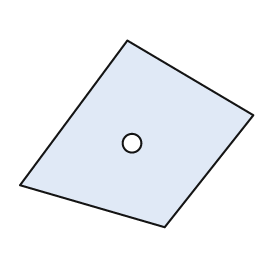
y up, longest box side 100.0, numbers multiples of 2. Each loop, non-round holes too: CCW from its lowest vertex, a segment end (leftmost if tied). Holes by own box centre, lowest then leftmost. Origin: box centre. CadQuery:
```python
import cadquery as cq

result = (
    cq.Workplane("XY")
    .moveTo(12.0, -40.0)
    .lineTo(50.0, 8.0)
    .lineTo(-4.0, 40.0)
    .lineTo(-50.0, -22.0)
    .close()
    .moveTo(-2.0, -4.0)
    .circle(4.0)
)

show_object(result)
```